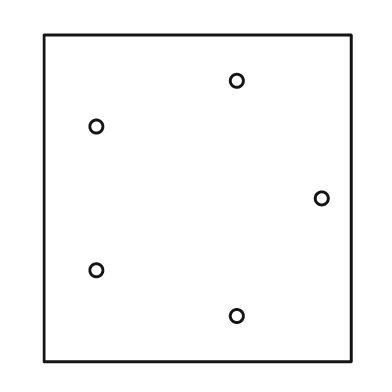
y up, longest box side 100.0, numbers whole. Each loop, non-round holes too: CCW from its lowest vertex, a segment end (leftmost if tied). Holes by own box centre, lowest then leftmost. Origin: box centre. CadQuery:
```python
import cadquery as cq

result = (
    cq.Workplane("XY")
    .moveTo(-47.0, -50.0)
    .lineTo(47.0, -50.0)
    .lineTo(47.0, 50.0)
    .lineTo(-47.0, 50.0)
    .close()
    .moveTo(12.0, -36.0)
    .circle(2.0)
    .moveTo(-31.0, -22.0)
    .circle(2.0)
    .moveTo(38.0, 0.0)
    .circle(2.0)
    .moveTo(-31.0, 22.0)
    .circle(2.0)
    .moveTo(12.0, 36.0)
    .circle(2.0)
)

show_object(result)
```